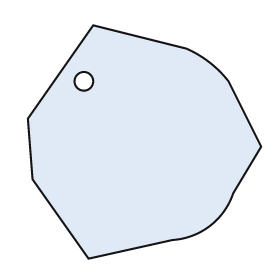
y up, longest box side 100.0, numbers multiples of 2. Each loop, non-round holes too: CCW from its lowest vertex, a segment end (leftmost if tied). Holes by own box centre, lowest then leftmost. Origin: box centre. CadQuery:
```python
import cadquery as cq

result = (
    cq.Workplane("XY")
    .moveTo(-24.0, -50.0)
    .lineTo(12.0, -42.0)
    .threePointArc((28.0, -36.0), (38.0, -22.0))
    .lineTo(50.0, -2.0)
    .lineTo(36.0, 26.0)
    .threePointArc((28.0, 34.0), (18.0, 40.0))
    .lineTo(-22.0, 50.0)
    .lineTo(-50.0, 10.0)
    .lineTo(-48.0, -16.0)
    .close()
    .moveTo(-26.0, 26.0)
    .circle(4.0)
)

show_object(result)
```